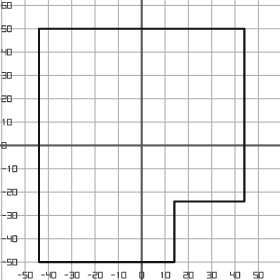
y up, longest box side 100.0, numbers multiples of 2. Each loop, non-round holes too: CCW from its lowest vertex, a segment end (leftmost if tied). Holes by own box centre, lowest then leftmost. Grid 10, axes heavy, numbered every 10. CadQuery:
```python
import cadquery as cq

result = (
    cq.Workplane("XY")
    .moveTo(-44.0, -50.0)
    .lineTo(14.0, -50.0)
    .lineTo(14.0, -24.0)
    .lineTo(44.0, -24.0)
    .lineTo(44.0, 50.0)
    .lineTo(-44.0, 50.0)
    .close()
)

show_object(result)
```